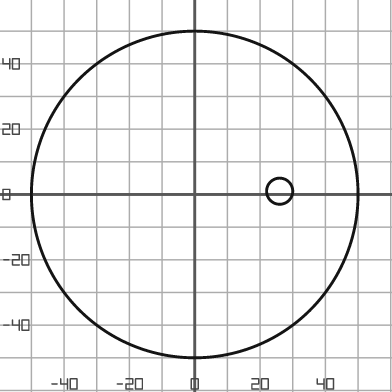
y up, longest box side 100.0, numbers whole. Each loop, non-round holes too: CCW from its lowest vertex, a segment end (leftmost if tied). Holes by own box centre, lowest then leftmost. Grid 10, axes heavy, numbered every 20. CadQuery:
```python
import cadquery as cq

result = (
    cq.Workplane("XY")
    .moveTo(0.0, 0.0)
    .circle(50.0)
    .moveTo(26.0, 1.0)
    .circle(4.0)
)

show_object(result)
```